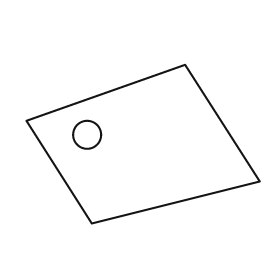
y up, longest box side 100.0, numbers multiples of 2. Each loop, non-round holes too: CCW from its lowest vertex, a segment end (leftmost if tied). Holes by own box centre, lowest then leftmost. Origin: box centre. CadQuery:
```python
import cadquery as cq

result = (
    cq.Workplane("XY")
    .moveTo(-22.0, -34.0)
    .lineTo(50.0, -16.0)
    .lineTo(18.0, 34.0)
    .lineTo(-50.0, 10.0)
    .close()
    .moveTo(-24.0, 4.0)
    .circle(6.0)
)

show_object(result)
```